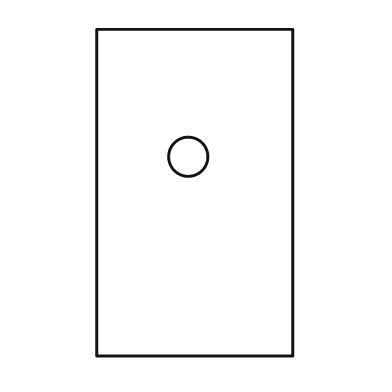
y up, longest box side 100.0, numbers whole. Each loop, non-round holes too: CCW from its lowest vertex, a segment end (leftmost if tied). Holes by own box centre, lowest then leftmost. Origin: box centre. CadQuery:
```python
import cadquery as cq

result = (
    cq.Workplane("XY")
    .moveTo(-30.0, -50.0)
    .lineTo(30.0, -50.0)
    .lineTo(30.0, 50.0)
    .lineTo(-30.0, 50.0)
    .close()
    .moveTo(-2.0, 11.0)
    .circle(6.0)
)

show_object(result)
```